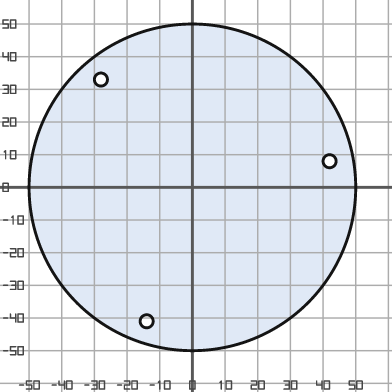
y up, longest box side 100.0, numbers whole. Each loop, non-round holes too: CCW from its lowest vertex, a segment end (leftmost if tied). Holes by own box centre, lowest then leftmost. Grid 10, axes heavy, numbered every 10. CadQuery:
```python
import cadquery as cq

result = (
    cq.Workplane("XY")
    .moveTo(0.0, 0.0)
    .circle(50.0)
    .moveTo(-14.0, -41.0)
    .circle(2.0)
    .moveTo(42.0, 8.0)
    .circle(2.0)
    .moveTo(-28.0, 33.0)
    .circle(2.0)
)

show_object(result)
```